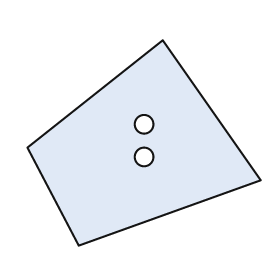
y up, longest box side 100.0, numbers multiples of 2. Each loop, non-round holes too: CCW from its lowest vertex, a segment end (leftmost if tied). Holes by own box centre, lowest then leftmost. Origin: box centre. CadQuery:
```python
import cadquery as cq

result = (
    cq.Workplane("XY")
    .moveTo(-28.0, -44.0)
    .lineTo(50.0, -16.0)
    .lineTo(8.0, 44.0)
    .lineTo(-50.0, -2.0)
    .close()
    .moveTo(0.0, -6.0)
    .circle(4.0)
    .moveTo(0.0, 8.0)
    .circle(4.0)
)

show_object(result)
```